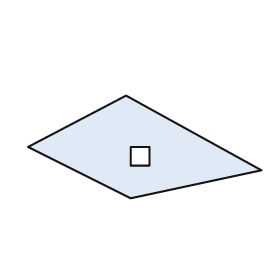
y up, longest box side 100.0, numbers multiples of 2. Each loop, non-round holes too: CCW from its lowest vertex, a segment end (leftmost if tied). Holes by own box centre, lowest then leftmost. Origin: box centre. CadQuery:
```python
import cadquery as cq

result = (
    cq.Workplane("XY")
    .moveTo(-6.0, -22.0)
    .lineTo(50.0, -10.0)
    .lineTo(-8.0, 22.0)
    .lineTo(-50.0, 0.0)
    .close()
    .moveTo(-6.0, -8.0)
    .lineTo(2.0, -8.0)
    .lineTo(2.0, 0.0)
    .lineTo(-6.0, 0.0)
    .close()
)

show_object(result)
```